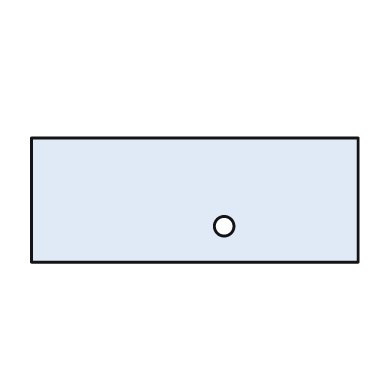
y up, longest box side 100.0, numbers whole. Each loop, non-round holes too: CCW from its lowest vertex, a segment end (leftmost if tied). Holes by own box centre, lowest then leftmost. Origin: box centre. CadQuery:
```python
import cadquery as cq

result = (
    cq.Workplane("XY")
    .moveTo(-50.0, -19.0)
    .lineTo(50.0, -19.0)
    .lineTo(50.0, 19.0)
    .lineTo(-50.0, 19.0)
    .close()
    .moveTo(9.0, -8.0)
    .circle(3.0)
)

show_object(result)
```